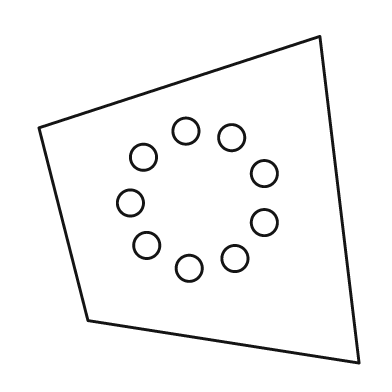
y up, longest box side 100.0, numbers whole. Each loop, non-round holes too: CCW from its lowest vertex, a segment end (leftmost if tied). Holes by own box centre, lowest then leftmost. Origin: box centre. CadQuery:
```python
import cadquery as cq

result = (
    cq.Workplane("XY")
    .moveTo(49.0, -50.0)
    .lineTo(37.0, 50.0)
    .lineTo(-49.0, 22.0)
    .lineTo(-34.0, -37.0)
    .close()
    .moveTo(-3.0, -21.0)
    .circle(4.0)
    .moveTo(11.0, -18.0)
    .circle(4.0)
    .moveTo(-16.0, -14.0)
    .circle(4.0)
    .moveTo(20.0, -7.0)
    .circle(4.0)
    .moveTo(-21.0, -1.0)
    .circle(4.0)
    .moveTo(20.0, 8.0)
    .circle(4.0)
    .moveTo(-17.0, 13.0)
    .circle(4.0)
    .moveTo(10.0, 19.0)
    .circle(4.0)
    .moveTo(-4.0, 21.0)
    .circle(4.0)
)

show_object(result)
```